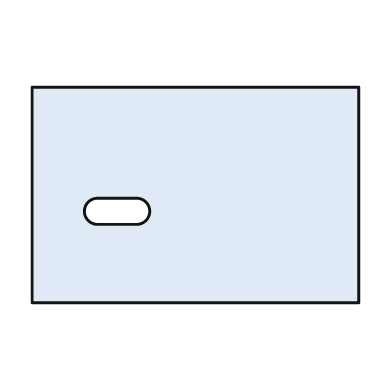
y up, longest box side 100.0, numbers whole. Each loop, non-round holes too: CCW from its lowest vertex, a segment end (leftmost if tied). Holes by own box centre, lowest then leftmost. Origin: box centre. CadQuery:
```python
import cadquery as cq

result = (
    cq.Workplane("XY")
    .moveTo(-50.0, -33.0)
    .lineTo(50.0, -33.0)
    .lineTo(50.0, 33.0)
    .lineTo(-50.0, 33.0)
    .close()
    .moveTo(-30.0, -9.0)
    .lineTo(-18.0, -9.0)
    .threePointArc((-14.0, -5.0), (-18.0, -1.0))
    .lineTo(-30.0, -1.0)
    .threePointArc((-34.0, -5.0), (-30.0, -9.0))
    .close()
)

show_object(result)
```